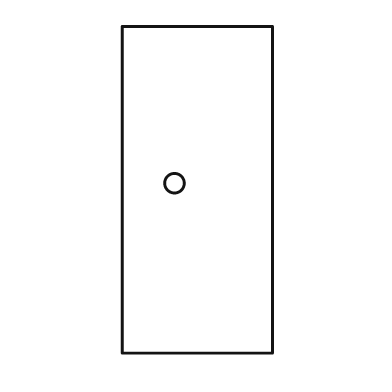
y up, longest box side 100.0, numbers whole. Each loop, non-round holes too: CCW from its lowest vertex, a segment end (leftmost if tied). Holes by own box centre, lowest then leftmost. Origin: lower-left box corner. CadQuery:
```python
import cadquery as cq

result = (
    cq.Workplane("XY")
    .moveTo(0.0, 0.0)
    .lineTo(46.0, 0.0)
    .lineTo(46.0, 100.0)
    .lineTo(0.0, 100.0)
    .close()
    .moveTo(16.0, 52.0)
    .circle(3.0)
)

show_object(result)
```